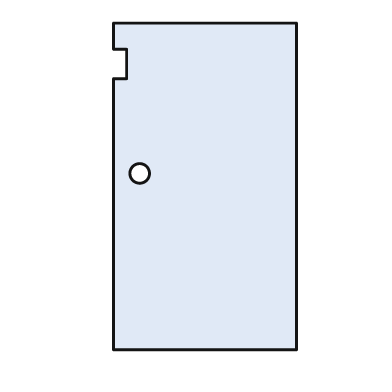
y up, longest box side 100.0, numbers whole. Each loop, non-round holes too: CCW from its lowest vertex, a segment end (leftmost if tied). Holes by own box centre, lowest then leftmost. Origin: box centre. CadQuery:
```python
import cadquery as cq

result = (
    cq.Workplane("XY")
    .moveTo(-28.0, -50.0)
    .lineTo(28.0, -50.0)
    .lineTo(28.0, 50.0)
    .lineTo(-28.0, 50.0)
    .lineTo(-28.0, 42.0)
    .lineTo(-24.0, 42.0)
    .lineTo(-24.0, 33.0)
    .lineTo(-28.0, 33.0)
    .close()
    .moveTo(-20.0, 4.0)
    .circle(3.0)
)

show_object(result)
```